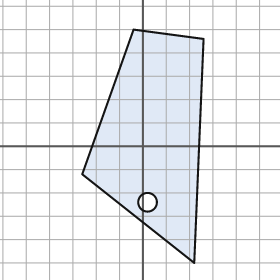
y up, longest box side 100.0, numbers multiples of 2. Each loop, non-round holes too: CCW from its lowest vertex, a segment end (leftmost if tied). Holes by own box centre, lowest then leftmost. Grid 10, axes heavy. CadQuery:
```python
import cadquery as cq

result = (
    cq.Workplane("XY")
    .moveTo(22.0, -50.0)
    .lineTo(26.0, 46.0)
    .lineTo(-4.0, 50.0)
    .lineTo(-26.0, -12.0)
    .close()
    .moveTo(2.0, -24.0)
    .circle(4.0)
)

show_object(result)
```